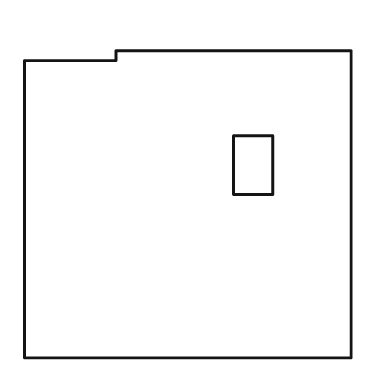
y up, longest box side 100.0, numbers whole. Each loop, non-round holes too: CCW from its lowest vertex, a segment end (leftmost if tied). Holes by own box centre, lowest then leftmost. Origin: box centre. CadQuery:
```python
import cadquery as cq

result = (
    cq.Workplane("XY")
    .moveTo(-50.0, -47.0)
    .lineTo(50.0, -47.0)
    .lineTo(50.0, 47.0)
    .lineTo(-22.0, 47.0)
    .lineTo(-22.0, 44.0)
    .lineTo(-50.0, 44.0)
    .close()
    .moveTo(14.0, 3.0)
    .lineTo(26.0, 3.0)
    .lineTo(26.0, 21.0)
    .lineTo(14.0, 21.0)
    .close()
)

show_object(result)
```